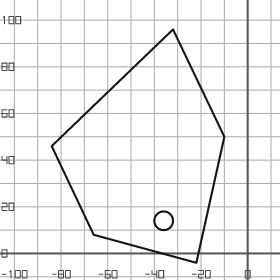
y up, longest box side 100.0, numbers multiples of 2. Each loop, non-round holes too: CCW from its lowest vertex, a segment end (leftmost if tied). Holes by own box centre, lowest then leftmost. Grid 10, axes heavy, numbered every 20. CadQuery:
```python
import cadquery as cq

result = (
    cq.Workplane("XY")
    .moveTo(-22.0, -4.0)
    .lineTo(-10.0, 50.0)
    .lineTo(-32.0, 96.0)
    .lineTo(-84.0, 46.0)
    .lineTo(-66.0, 8.0)
    .close()
    .moveTo(-36.0, 14.0)
    .circle(4.0)
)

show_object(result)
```